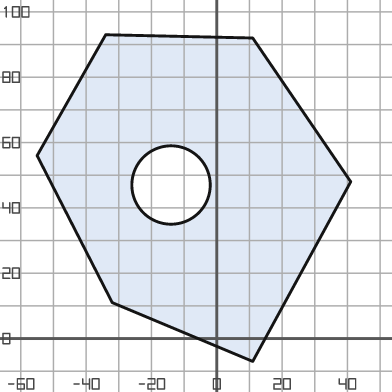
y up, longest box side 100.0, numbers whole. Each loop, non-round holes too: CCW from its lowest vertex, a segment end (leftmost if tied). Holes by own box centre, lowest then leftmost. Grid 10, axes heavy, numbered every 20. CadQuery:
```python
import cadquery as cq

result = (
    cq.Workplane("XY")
    .moveTo(11.0, -7.0)
    .lineTo(41.0, 48.0)
    .lineTo(11.0, 92.0)
    .lineTo(-34.0, 93.0)
    .lineTo(-55.0, 56.0)
    .lineTo(-32.0, 11.0)
    .close()
    .moveTo(-14.0, 47.0)
    .circle(12.0)
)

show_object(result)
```